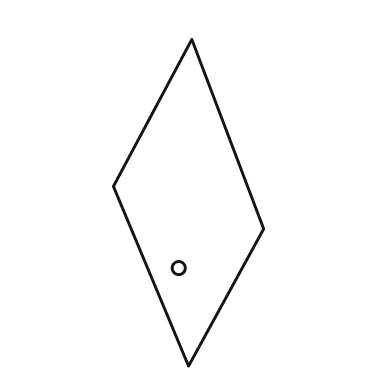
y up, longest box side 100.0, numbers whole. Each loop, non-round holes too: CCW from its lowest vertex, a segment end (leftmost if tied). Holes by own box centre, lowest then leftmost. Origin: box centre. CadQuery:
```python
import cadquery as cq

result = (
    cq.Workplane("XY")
    .moveTo(0.0, -50.0)
    .lineTo(23.0, -8.0)
    .lineTo(1.0, 50.0)
    .lineTo(-23.0, 5.0)
    .close()
    .moveTo(-3.0, -20.0)
    .circle(2.0)
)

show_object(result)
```